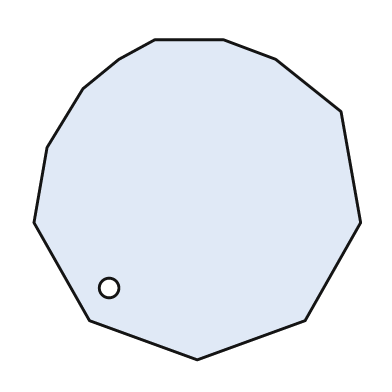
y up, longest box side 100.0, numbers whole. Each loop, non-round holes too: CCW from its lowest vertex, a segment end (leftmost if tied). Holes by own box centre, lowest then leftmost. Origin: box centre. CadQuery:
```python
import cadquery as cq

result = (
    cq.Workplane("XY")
    .moveTo(0.0, -49.0)
    .lineTo(33.0, -37.0)
    .lineTo(50.0, -7.0)
    .lineTo(44.0, 27.0)
    .lineTo(24.0, 43.0)
    .lineTo(8.0, 49.0)
    .lineTo(-13.0, 49.0)
    .lineTo(-24.0, 43.0)
    .lineTo(-35.0, 34.0)
    .lineTo(-46.0, 16.0)
    .lineTo(-50.0, -7.0)
    .lineTo(-33.0, -37.0)
    .close()
    .moveTo(-27.0, -27.0)
    .circle(3.0)
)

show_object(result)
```